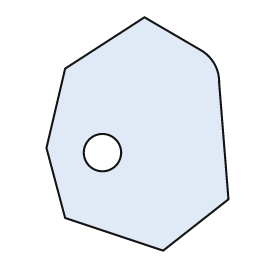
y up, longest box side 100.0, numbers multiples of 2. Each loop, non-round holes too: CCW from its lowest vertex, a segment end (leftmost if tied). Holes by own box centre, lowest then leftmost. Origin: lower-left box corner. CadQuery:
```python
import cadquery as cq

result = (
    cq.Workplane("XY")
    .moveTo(50.0, 0.0)
    .lineTo(78.0, 22.0)
    .lineTo(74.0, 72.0)
    .threePointArc((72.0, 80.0), (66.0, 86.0))
    .lineTo(42.0, 100.0)
    .lineTo(8.0, 78.0)
    .lineTo(0.0, 44.0)
    .lineTo(8.0, 14.0)
    .close()
    .moveTo(24.0, 42.0)
    .circle(8.0)
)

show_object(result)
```